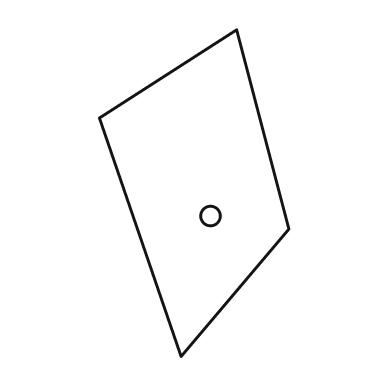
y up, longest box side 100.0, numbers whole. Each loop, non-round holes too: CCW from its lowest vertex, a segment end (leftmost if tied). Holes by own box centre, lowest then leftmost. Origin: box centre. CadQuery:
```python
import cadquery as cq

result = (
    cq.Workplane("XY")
    .moveTo(-4.0, -50.0)
    .lineTo(29.0, -11.0)
    .lineTo(13.0, 50.0)
    .lineTo(-29.0, 23.0)
    .close()
    .moveTo(5.0, -7.0)
    .circle(3.0)
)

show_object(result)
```